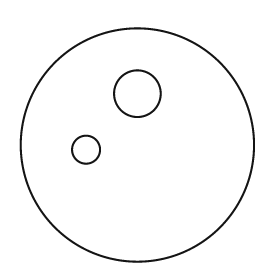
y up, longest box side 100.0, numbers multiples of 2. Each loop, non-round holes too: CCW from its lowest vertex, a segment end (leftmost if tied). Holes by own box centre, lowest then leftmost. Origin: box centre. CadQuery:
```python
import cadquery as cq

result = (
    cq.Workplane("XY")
    .moveTo(0.0, 0.0)
    .circle(50.0)
    .moveTo(-22.0, -2.0)
    .circle(6.0)
    .moveTo(0.0, 22.0)
    .circle(10.0)
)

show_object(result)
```